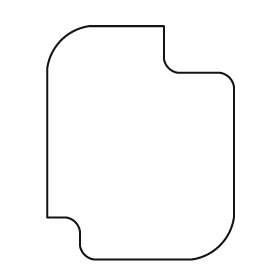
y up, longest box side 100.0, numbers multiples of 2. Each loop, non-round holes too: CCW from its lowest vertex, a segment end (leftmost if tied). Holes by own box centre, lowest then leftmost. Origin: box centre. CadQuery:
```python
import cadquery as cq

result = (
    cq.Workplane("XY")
    .moveTo(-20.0, -50.0)
    .lineTo(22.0, -50.0)
    .threePointArc((34.0, -44.0), (40.0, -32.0))
    .lineTo(40.0, 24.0)
    .threePointArc((38.0, 28.0), (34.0, 30.0))
    .lineTo(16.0, 30.0)
    .threePointArc((12.0, 32.0), (10.0, 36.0))
    .lineTo(10.0, 50.0)
    .lineTo(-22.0, 50.0)
    .threePointArc((-34.0, 44.0), (-40.0, 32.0))
    .lineTo(-40.0, -32.0)
    .lineTo(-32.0, -32.0)
    .threePointArc((-28.0, -34.0), (-26.0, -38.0))
    .lineTo(-26.0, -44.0)
    .threePointArc((-24.0, -48.0), (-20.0, -50.0))
    .close()
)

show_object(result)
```